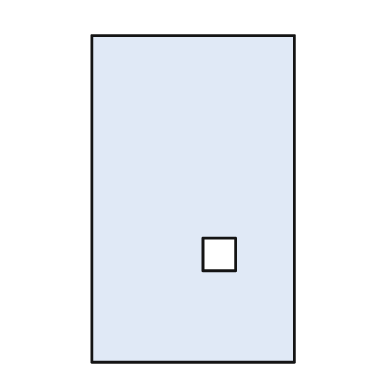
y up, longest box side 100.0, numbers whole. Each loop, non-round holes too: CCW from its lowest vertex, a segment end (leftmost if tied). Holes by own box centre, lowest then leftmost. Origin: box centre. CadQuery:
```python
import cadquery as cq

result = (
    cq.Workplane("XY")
    .moveTo(-31.0, -50.0)
    .lineTo(31.0, -50.0)
    .lineTo(31.0, 50.0)
    .lineTo(-31.0, 50.0)
    .close()
    .moveTo(3.0, -22.0)
    .lineTo(13.0, -22.0)
    .lineTo(13.0, -12.0)
    .lineTo(3.0, -12.0)
    .close()
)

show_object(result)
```